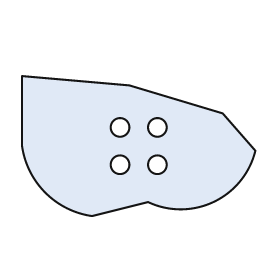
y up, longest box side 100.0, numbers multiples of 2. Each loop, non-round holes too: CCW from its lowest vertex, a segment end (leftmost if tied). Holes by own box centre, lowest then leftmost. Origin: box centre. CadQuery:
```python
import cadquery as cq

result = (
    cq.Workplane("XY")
    .moveTo(-20.0, -30.0)
    .lineTo(4.0, -24.0)
    .threePointArc((32.0, -24.0), (50.0, -2.0))
    .lineTo(36.0, 14.0)
    .lineTo(-4.0, 26.0)
    .lineTo(-50.0, 30.0)
    .lineTo(-50.0, 0.0)
    .threePointArc((-40.0, -20.0), (-20.0, -30.0))
    .close()
    .moveTo(-8.0, -8.0)
    .circle(4.0)
    .moveTo(8.0, -8.0)
    .circle(4.0)
    .moveTo(-8.0, 8.0)
    .circle(4.0)
    .moveTo(8.0, 8.0)
    .circle(4.0)
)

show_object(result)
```